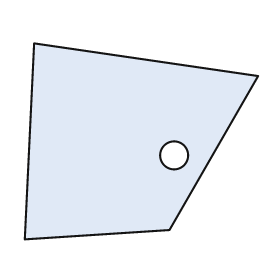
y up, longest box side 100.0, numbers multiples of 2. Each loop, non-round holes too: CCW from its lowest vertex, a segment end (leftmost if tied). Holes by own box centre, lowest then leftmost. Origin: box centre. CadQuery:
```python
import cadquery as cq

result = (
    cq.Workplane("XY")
    .moveTo(-50.0, -42.0)
    .lineTo(12.0, -38.0)
    .lineTo(50.0, 28.0)
    .lineTo(-46.0, 42.0)
    .close()
    .moveTo(14.0, -6.0)
    .circle(6.0)
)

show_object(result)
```